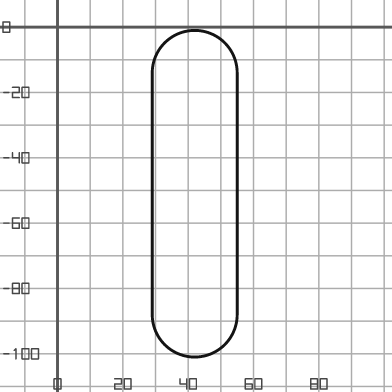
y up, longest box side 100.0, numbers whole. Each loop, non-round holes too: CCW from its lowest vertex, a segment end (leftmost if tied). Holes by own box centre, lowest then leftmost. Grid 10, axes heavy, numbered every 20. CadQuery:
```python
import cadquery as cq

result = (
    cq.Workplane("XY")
    .moveTo(29.0, -88.0)
    .threePointArc((42.0, -101.0), (55.0, -88.0))
    .lineTo(55.0, -14.0)
    .threePointArc((42.0, -1.0), (29.0, -14.0))
    .close()
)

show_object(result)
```